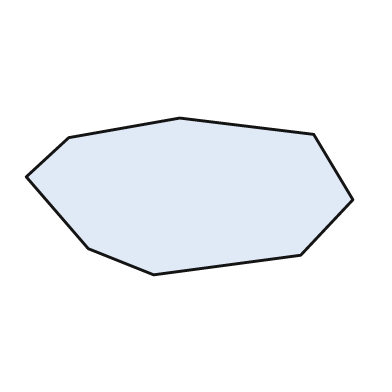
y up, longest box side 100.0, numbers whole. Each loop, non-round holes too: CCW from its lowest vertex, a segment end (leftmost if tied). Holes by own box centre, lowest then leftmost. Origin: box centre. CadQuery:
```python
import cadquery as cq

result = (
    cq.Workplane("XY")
    .moveTo(-11.0, -24.0)
    .lineTo(34.0, -18.0)
    .lineTo(50.0, -1.0)
    .lineTo(38.0, 19.0)
    .lineTo(-3.0, 24.0)
    .lineTo(-37.0, 18.0)
    .lineTo(-50.0, 6.0)
    .lineTo(-31.0, -16.0)
    .close()
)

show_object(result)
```